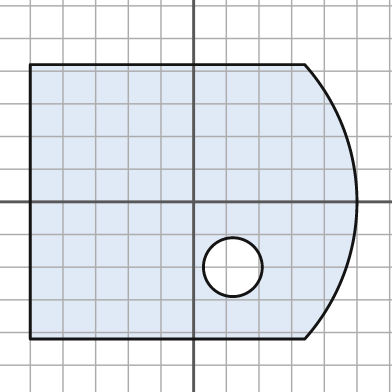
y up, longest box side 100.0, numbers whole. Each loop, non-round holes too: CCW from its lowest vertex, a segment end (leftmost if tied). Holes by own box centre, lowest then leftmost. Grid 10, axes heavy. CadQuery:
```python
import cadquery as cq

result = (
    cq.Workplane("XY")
    .moveTo(-50.0, -42.0)
    .lineTo(34.0, -42.0)
    .threePointArc((50.0, 0.0), (34.0, 42.0))
    .lineTo(-50.0, 42.0)
    .close()
    .moveTo(12.0, -20.0)
    .circle(9.0)
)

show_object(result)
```